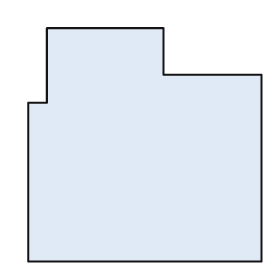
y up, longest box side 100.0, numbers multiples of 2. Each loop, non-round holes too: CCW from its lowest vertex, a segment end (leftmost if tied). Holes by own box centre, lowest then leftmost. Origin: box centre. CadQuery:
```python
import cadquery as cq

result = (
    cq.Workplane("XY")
    .moveTo(-50.0, -50.0)
    .lineTo(50.0, -50.0)
    .lineTo(50.0, 30.0)
    .lineTo(8.0, 30.0)
    .lineTo(8.0, 50.0)
    .lineTo(-42.0, 50.0)
    .lineTo(-42.0, 18.0)
    .lineTo(-50.0, 18.0)
    .close()
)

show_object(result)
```